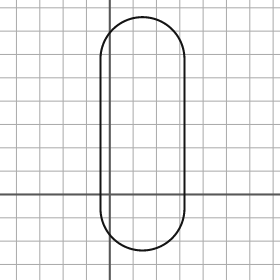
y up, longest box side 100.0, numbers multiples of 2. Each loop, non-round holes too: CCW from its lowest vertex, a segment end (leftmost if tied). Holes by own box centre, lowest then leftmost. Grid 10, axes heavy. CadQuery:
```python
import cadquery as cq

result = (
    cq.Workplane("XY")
    .moveTo(-4.0, -6.0)
    .threePointArc((14.0, -24.0), (32.0, -6.0))
    .lineTo(32.0, 58.0)
    .threePointArc((14.0, 76.0), (-4.0, 58.0))
    .close()
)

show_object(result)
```